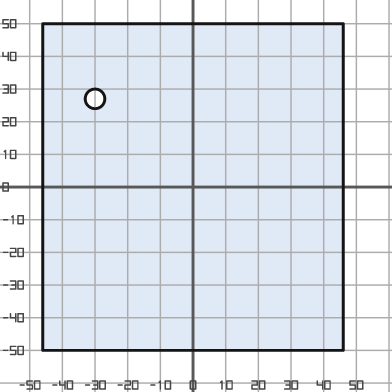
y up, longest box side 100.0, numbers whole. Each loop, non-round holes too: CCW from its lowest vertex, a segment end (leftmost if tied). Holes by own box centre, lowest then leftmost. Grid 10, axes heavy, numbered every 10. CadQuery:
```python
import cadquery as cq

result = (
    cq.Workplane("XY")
    .moveTo(-46.0, -50.0)
    .lineTo(46.0, -50.0)
    .lineTo(46.0, 50.0)
    .lineTo(-46.0, 50.0)
    .close()
    .moveTo(-30.0, 27.0)
    .circle(3.0)
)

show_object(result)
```